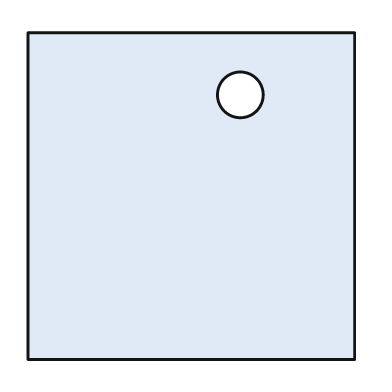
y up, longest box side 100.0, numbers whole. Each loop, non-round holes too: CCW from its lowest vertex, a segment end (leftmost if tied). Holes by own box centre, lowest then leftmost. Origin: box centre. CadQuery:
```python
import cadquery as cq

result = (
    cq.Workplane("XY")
    .moveTo(-50.0, -50.0)
    .lineTo(50.0, -50.0)
    .lineTo(50.0, 50.0)
    .lineTo(-50.0, 50.0)
    .close()
    .moveTo(15.0, 31.0)
    .circle(7.0)
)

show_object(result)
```